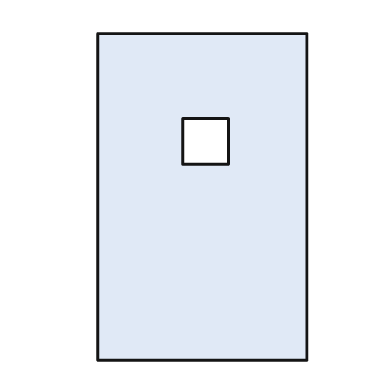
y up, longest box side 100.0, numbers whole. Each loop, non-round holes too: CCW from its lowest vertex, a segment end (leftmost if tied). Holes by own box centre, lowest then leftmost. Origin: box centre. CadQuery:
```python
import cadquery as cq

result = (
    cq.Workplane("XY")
    .moveTo(-32.0, -50.0)
    .lineTo(32.0, -50.0)
    .lineTo(32.0, 50.0)
    .lineTo(-32.0, 50.0)
    .close()
    .moveTo(-6.0, 10.0)
    .lineTo(8.0, 10.0)
    .lineTo(8.0, 24.0)
    .lineTo(-6.0, 24.0)
    .close()
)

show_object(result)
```